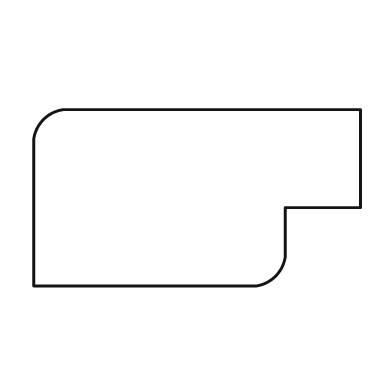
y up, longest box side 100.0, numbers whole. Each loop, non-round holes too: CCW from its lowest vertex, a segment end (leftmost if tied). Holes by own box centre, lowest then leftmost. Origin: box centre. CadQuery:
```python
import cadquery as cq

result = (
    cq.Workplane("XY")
    .moveTo(-50.0, -27.0)
    .lineTo(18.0, -27.0)
    .threePointArc((24.0, -24.0), (27.0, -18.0))
    .lineTo(27.0, -3.0)
    .lineTo(50.0, -3.0)
    .lineTo(50.0, 27.0)
    .lineTo(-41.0, 27.0)
    .threePointArc((-47.0, 24.0), (-50.0, 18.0))
    .close()
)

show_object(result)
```